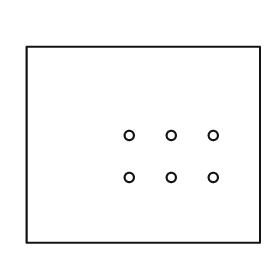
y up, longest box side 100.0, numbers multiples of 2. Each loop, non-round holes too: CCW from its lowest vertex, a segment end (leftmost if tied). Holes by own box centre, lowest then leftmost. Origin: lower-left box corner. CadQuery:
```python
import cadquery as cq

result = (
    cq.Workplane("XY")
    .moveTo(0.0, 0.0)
    .lineTo(100.0, 0.0)
    .lineTo(100.0, 84.0)
    .lineTo(0.0, 84.0)
    .close()
    .moveTo(44.0, 28.0)
    .circle(2.0)
    .moveTo(62.0, 28.0)
    .circle(2.0)
    .moveTo(80.0, 28.0)
    .circle(2.0)
    .moveTo(44.0, 46.0)
    .circle(2.0)
    .moveTo(62.0, 46.0)
    .circle(2.0)
    .moveTo(80.0, 46.0)
    .circle(2.0)
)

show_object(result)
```